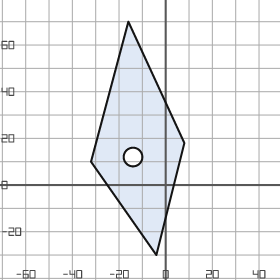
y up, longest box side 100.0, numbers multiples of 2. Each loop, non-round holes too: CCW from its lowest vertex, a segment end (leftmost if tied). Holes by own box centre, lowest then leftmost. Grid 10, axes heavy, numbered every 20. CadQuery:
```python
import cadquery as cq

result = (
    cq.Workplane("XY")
    .moveTo(-4.0, -30.0)
    .lineTo(8.0, 18.0)
    .lineTo(-16.0, 70.0)
    .lineTo(-32.0, 10.0)
    .close()
    .moveTo(-14.0, 12.0)
    .circle(4.0)
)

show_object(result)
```